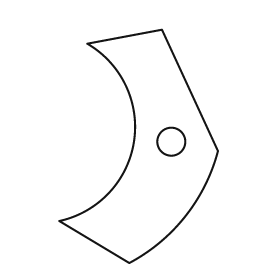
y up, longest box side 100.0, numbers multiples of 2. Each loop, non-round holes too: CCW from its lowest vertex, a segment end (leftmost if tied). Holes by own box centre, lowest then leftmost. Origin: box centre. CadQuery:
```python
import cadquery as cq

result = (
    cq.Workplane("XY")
    .moveTo(-4.0, -50.0)
    .threePointArc((20.0, -30.0), (34.0, -2.0))
    .lineTo(10.0, 50.0)
    .lineTo(-22.0, 44.0)
    .threePointArc((-2.0, 2.0), (-34.0, -32.0))
    .close()
    .moveTo(14.0, 2.0)
    .circle(6.0)
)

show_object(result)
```